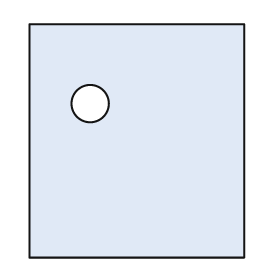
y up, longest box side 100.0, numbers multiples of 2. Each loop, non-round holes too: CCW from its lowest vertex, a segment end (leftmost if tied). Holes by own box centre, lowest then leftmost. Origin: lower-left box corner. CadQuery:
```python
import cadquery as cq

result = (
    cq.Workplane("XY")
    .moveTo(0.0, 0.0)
    .lineTo(92.0, 0.0)
    .lineTo(92.0, 100.0)
    .lineTo(0.0, 100.0)
    .close()
    .moveTo(26.0, 66.0)
    .circle(8.0)
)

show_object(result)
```